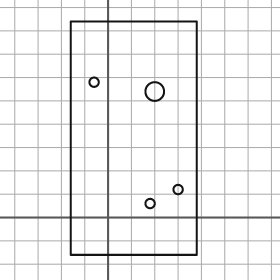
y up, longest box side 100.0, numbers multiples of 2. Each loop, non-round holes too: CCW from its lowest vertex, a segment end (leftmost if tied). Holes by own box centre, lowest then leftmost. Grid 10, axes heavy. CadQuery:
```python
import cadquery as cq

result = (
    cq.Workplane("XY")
    .moveTo(-16.0, -16.0)
    .lineTo(38.0, -16.0)
    .lineTo(38.0, 84.0)
    .lineTo(-16.0, 84.0)
    .close()
    .moveTo(18.0, 6.0)
    .circle(2.0)
    .moveTo(30.0, 12.0)
    .circle(2.0)
    .moveTo(20.0, 54.0)
    .circle(4.0)
    .moveTo(-6.0, 58.0)
    .circle(2.0)
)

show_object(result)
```